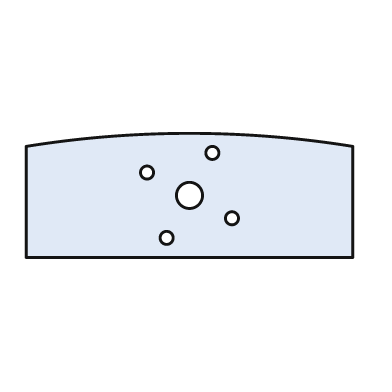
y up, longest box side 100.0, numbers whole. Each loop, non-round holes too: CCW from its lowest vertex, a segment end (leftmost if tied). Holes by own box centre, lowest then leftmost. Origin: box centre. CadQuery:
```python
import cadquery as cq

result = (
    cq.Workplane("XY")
    .moveTo(-50.0, -19.0)
    .lineTo(50.0, -19.0)
    .lineTo(50.0, 15.0)
    .threePointArc((0.0, 19.0), (-50.0, 15.0))
    .close()
    .moveTo(-7.0, -13.0)
    .circle(2.0)
    .moveTo(13.0, -7.0)
    .circle(2.0)
    .moveTo(0.0, 0.0)
    .circle(4.0)
    .moveTo(-13.0, 7.0)
    .circle(2.0)
    .moveTo(7.0, 13.0)
    .circle(2.0)
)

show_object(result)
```